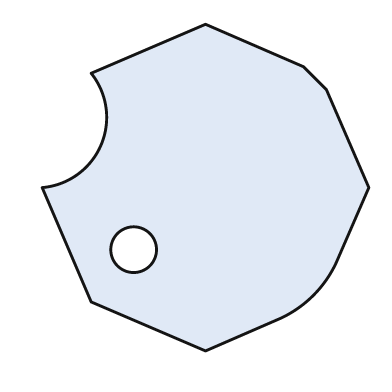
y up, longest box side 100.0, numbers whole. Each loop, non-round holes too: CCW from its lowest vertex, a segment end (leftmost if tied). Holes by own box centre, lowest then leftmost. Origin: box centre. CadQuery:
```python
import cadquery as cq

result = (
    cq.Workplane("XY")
    .moveTo(0.0, -50.0)
    .lineTo(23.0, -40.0)
    .threePointArc((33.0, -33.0), (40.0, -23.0))
    .lineTo(50.0, 0.0)
    .lineTo(37.0, 30.0)
    .lineTo(30.0, 37.0)
    .lineTo(0.0, 50.0)
    .lineTo(-35.0, 35.0)
    .threePointArc((-32.0, 13.0), (-50.0, 0.0))
    .lineTo(-35.0, -35.0)
    .close()
    .moveTo(-22.0, -19.0)
    .circle(7.0)
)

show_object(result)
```